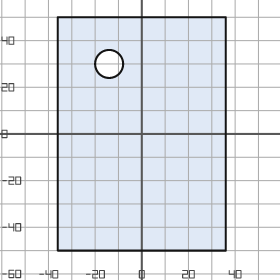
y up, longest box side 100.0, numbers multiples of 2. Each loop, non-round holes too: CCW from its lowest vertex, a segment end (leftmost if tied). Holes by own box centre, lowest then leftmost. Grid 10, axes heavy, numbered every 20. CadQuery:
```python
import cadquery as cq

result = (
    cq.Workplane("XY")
    .moveTo(-36.0, -50.0)
    .lineTo(36.0, -50.0)
    .lineTo(36.0, 50.0)
    .lineTo(-36.0, 50.0)
    .close()
    .moveTo(-14.0, 30.0)
    .circle(6.0)
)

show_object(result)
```